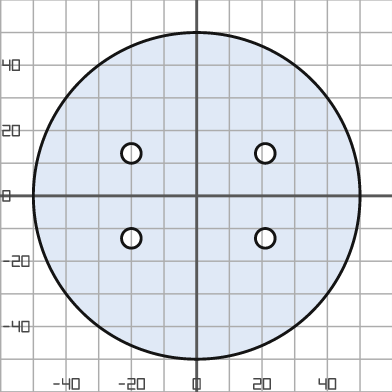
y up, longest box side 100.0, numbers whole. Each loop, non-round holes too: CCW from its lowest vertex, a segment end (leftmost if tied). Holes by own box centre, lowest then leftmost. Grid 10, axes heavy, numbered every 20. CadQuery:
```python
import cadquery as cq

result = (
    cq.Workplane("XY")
    .moveTo(0.0, 0.0)
    .circle(50.0)
    .moveTo(-20.0, -13.0)
    .circle(3.0)
    .moveTo(21.0, -13.0)
    .circle(3.0)
    .moveTo(-20.0, 13.0)
    .circle(3.0)
    .moveTo(21.0, 13.0)
    .circle(3.0)
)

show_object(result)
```